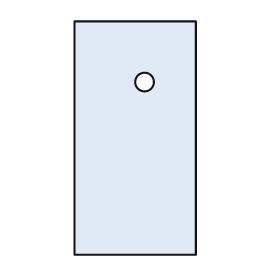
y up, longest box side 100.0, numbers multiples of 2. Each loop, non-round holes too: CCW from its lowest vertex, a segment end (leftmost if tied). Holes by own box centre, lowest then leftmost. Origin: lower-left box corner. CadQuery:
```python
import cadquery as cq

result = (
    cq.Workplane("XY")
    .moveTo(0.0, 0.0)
    .lineTo(52.0, 0.0)
    .lineTo(52.0, 100.0)
    .lineTo(0.0, 100.0)
    .close()
    .moveTo(30.0, 74.0)
    .circle(4.0)
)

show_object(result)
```